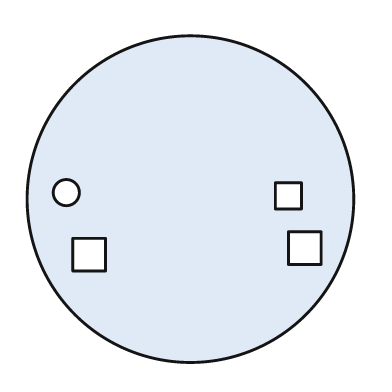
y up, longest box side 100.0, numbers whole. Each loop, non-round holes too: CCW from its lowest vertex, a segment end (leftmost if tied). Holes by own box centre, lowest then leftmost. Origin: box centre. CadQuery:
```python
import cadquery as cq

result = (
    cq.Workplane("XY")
    .moveTo(0.0, 0.0)
    .circle(50.0)
    .moveTo(-36.0, -22.0)
    .lineTo(-26.0, -22.0)
    .lineTo(-26.0, -12.0)
    .lineTo(-36.0, -12.0)
    .close()
    .moveTo(30.0, -20.0)
    .lineTo(40.0, -20.0)
    .lineTo(40.0, -10.0)
    .lineTo(30.0, -10.0)
    .close()
    .moveTo(26.0, -3.0)
    .lineTo(34.0, -3.0)
    .lineTo(34.0, 5.0)
    .lineTo(26.0, 5.0)
    .close()
    .moveTo(-38.0, 2.0)
    .circle(4.0)
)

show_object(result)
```